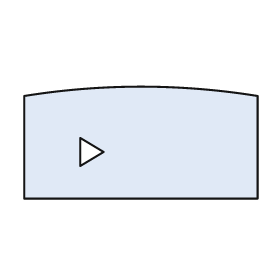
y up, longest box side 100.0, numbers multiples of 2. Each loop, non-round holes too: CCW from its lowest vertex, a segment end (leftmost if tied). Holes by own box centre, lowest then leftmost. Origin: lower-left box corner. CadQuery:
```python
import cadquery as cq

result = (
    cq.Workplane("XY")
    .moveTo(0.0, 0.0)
    .lineTo(100.0, 0.0)
    .lineTo(100.0, 44.0)
    .threePointArc((50.0, 48.0), (0.0, 44.0))
    .close()
    .moveTo(24.0, 14.0)
    .lineTo(34.0, 20.0)
    .lineTo(24.0, 26.0)
    .close()
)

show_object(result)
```